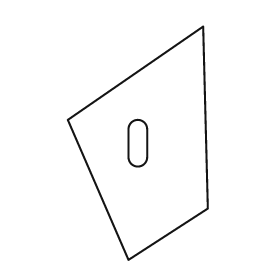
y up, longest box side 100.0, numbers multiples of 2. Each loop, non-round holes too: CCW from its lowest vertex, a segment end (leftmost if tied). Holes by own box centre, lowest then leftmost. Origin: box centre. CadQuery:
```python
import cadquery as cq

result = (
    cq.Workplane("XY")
    .moveTo(-4.0, -50.0)
    .lineTo(30.0, -28.0)
    .lineTo(28.0, 50.0)
    .lineTo(-30.0, 10.0)
    .close()
    .moveTo(-4.0, -6.0)
    .threePointArc((0.0, -10.0), (4.0, -6.0))
    .lineTo(4.0, 6.0)
    .threePointArc((0.0, 10.0), (-4.0, 6.0))
    .close()
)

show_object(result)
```